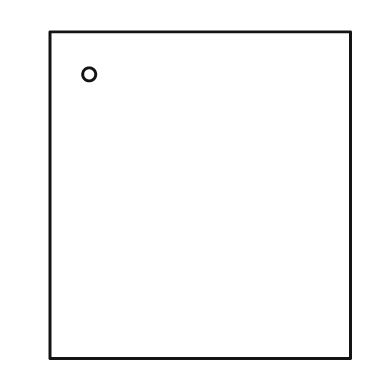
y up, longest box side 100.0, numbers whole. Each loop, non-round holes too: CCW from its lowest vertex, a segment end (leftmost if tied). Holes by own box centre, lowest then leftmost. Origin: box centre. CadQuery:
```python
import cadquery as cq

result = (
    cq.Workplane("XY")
    .moveTo(-46.0, -50.0)
    .lineTo(46.0, -50.0)
    .lineTo(46.0, 50.0)
    .lineTo(-46.0, 50.0)
    .close()
    .moveTo(-34.0, 37.0)
    .circle(2.0)
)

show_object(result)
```